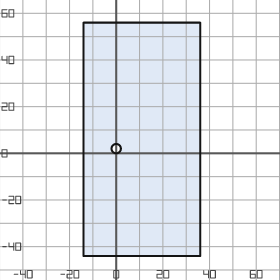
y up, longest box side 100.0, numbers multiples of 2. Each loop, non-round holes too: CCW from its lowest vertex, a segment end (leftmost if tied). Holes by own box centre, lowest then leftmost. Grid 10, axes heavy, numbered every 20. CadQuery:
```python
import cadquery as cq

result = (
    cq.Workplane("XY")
    .moveTo(-14.0, -44.0)
    .lineTo(36.0, -44.0)
    .lineTo(36.0, 56.0)
    .lineTo(-14.0, 56.0)
    .close()
    .moveTo(0.0, 2.0)
    .circle(2.0)
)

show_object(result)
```